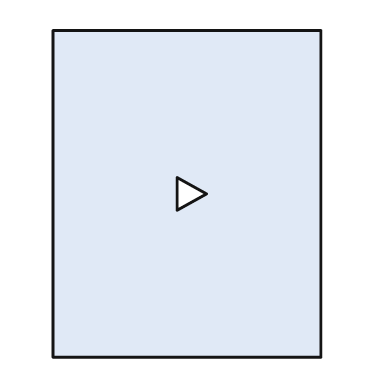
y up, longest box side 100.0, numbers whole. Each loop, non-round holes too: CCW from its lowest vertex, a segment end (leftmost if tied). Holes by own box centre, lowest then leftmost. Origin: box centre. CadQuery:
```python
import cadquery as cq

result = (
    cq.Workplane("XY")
    .moveTo(-41.0, -50.0)
    .lineTo(41.0, -50.0)
    .lineTo(41.0, 50.0)
    .lineTo(-41.0, 50.0)
    .close()
    .moveTo(-3.0, -5.0)
    .lineTo(6.0, 0.0)
    .lineTo(-3.0, 5.0)
    .close()
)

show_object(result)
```